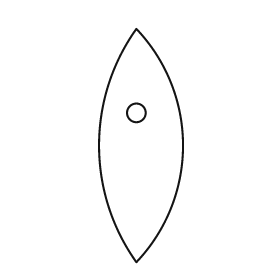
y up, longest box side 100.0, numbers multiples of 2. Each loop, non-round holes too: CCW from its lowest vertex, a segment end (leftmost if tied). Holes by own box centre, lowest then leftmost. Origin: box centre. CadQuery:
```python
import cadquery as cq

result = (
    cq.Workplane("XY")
    .moveTo(-2.0, -50.0)
    .threePointArc((18.0, 0.0), (-2.0, 50.0))
    .threePointArc((-18.0, 0.0), (-2.0, -50.0))
    .close()
    .moveTo(-2.0, 14.0)
    .circle(4.0)
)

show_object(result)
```